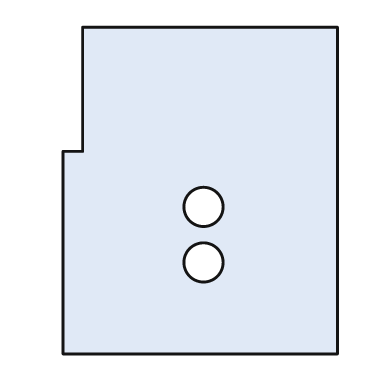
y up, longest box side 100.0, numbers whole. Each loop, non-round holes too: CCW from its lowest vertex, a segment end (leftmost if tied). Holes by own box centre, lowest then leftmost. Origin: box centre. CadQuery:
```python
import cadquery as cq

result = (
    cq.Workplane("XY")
    .moveTo(-42.0, -50.0)
    .lineTo(42.0, -50.0)
    .lineTo(42.0, 50.0)
    .lineTo(-36.0, 50.0)
    .lineTo(-36.0, 12.0)
    .lineTo(-42.0, 12.0)
    .close()
    .moveTo(1.0, -22.0)
    .circle(6.0)
    .moveTo(1.0, -5.0)
    .circle(6.0)
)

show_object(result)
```